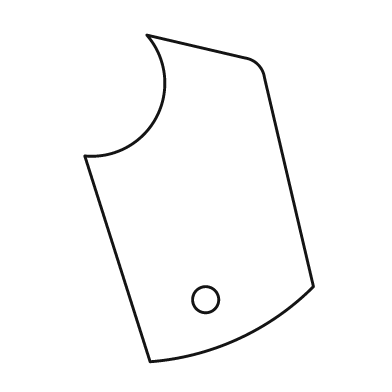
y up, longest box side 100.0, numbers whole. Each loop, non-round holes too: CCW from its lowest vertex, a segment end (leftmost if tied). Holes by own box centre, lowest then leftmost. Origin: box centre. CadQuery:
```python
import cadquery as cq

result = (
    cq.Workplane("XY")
    .moveTo(-15.0, -50.0)
    .threePointArc((12.0, -43.0), (35.0, -27.0))
    .lineTo(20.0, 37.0)
    .threePointArc((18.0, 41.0), (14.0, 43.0))
    .lineTo(-16.0, 50.0)
    .threePointArc((-13.0, 25.0), (-35.0, 13.0))
    .close()
    .moveTo(2.0, -31.0)
    .circle(4.0)
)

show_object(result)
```